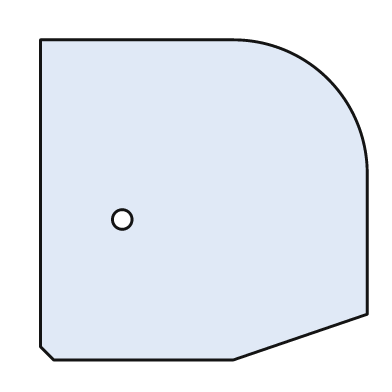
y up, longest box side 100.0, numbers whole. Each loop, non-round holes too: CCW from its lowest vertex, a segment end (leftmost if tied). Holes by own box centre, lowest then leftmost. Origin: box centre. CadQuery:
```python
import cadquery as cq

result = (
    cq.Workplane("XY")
    .moveTo(-46.0, -49.0)
    .lineTo(9.0, -49.0)
    .lineTo(50.0, -35.0)
    .lineTo(50.0, 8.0)
    .threePointArc((38.0, 37.0), (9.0, 49.0))
    .lineTo(-50.0, 49.0)
    .lineTo(-50.0, -45.0)
    .close()
    .moveTo(-25.0, -6.0)
    .circle(3.0)
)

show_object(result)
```